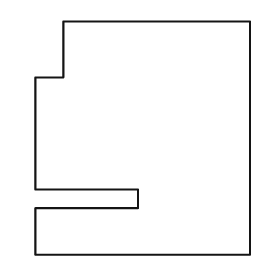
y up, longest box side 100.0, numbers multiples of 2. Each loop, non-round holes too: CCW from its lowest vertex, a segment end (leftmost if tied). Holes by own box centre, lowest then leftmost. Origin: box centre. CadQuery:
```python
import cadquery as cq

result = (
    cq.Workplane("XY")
    .moveTo(-46.0, -50.0)
    .lineTo(46.0, -50.0)
    .lineTo(46.0, 50.0)
    .lineTo(-34.0, 50.0)
    .lineTo(-34.0, 26.0)
    .lineTo(-46.0, 26.0)
    .lineTo(-46.0, -22.0)
    .lineTo(-2.0, -22.0)
    .lineTo(-2.0, -30.0)
    .lineTo(-46.0, -30.0)
    .close()
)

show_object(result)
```